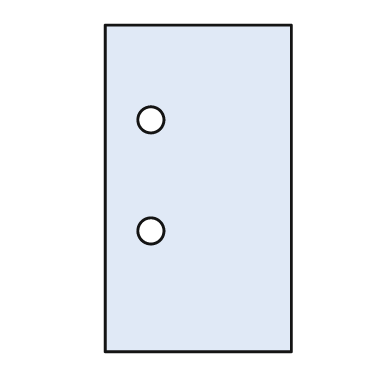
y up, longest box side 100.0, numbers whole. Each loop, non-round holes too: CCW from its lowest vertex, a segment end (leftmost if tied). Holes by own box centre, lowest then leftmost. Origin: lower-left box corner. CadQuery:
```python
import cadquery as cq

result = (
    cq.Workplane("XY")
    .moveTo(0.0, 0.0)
    .lineTo(57.0, 0.0)
    .lineTo(57.0, 100.0)
    .lineTo(0.0, 100.0)
    .close()
    .moveTo(14.0, 37.0)
    .circle(4.0)
    .moveTo(14.0, 71.0)
    .circle(4.0)
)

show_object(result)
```